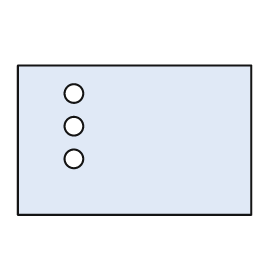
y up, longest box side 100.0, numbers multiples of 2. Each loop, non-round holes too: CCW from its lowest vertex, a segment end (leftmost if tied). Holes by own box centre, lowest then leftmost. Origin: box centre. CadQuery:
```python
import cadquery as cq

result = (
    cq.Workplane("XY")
    .moveTo(-50.0, -32.0)
    .lineTo(50.0, -32.0)
    .lineTo(50.0, 32.0)
    .lineTo(-50.0, 32.0)
    .close()
    .moveTo(-26.0, -8.0)
    .circle(4.0)
    .moveTo(-26.0, 6.0)
    .circle(4.0)
    .moveTo(-26.0, 20.0)
    .circle(4.0)
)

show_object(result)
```